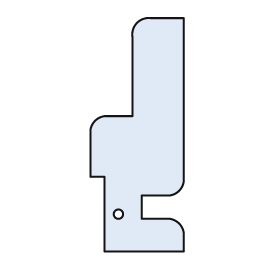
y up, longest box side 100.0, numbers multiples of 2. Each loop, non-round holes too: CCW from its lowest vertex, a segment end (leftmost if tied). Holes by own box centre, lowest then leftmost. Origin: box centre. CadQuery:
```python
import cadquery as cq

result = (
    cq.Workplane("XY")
    .moveTo(-14.0, -50.0)
    .lineTo(20.0, -50.0)
    .lineTo(20.0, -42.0)
    .threePointArc((18.0, -38.0), (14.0, -36.0))
    .lineTo(2.0, -36.0)
    .lineTo(2.0, -26.0)
    .lineTo(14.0, -26.0)
    .threePointArc((18.0, -24.0), (20.0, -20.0))
    .lineTo(20.0, 50.0)
    .lineTo(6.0, 50.0)
    .threePointArc((0.0, 48.0), (-2.0, 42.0))
    .lineTo(-2.0, 8.0)
    .lineTo(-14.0, 8.0)
    .threePointArc((-18.0, 6.0), (-20.0, 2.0))
    .lineTo(-20.0, -18.0)
    .lineTo(-14.0, -18.0)
    .close()
    .moveTo(-8.0, -34.0)
    .circle(2.0)
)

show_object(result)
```